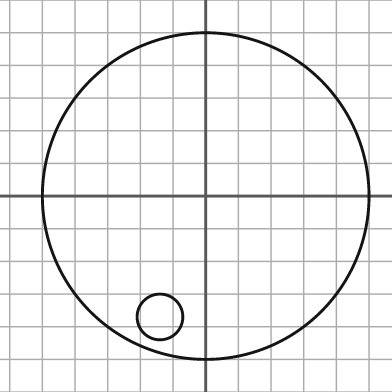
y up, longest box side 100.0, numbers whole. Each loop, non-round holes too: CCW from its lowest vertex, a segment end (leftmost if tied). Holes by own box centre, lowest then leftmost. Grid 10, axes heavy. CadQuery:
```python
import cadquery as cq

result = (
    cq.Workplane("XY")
    .moveTo(0.0, 0.0)
    .circle(50.0)
    .moveTo(-14.0, -37.0)
    .circle(7.0)
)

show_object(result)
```